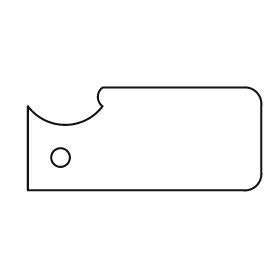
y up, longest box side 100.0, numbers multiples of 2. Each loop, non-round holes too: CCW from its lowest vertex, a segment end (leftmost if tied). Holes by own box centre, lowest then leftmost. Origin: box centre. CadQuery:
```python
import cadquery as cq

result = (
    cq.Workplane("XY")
    .moveTo(-50.0, -22.0)
    .lineTo(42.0, -22.0)
    .threePointArc((48.0, -20.0), (50.0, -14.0))
    .lineTo(50.0, 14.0)
    .threePointArc((48.0, 20.0), (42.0, 22.0))
    .lineTo(-18.0, 22.0)
    .threePointArc((-20.0, 18.0), (-18.0, 14.0))
    .threePointArc((-34.0, 6.0), (-50.0, 14.0))
    .close()
    .moveTo(-36.0, -8.0)
    .circle(4.0)
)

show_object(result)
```